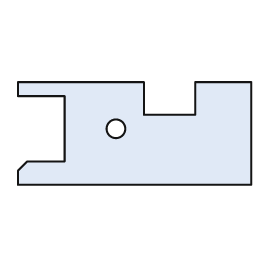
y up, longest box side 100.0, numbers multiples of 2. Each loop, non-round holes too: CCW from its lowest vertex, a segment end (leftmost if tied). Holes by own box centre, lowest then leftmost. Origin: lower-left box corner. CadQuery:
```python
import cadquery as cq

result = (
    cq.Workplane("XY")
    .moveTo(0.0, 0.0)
    .lineTo(100.0, 0.0)
    .lineTo(100.0, 44.0)
    .lineTo(76.0, 44.0)
    .lineTo(76.0, 30.0)
    .lineTo(54.0, 30.0)
    .lineTo(54.0, 44.0)
    .lineTo(0.0, 44.0)
    .lineTo(0.0, 38.0)
    .lineTo(20.0, 38.0)
    .lineTo(20.0, 10.0)
    .lineTo(4.0, 10.0)
    .lineTo(0.0, 6.0)
    .close()
    .moveTo(42.0, 24.0)
    .circle(4.0)
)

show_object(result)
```